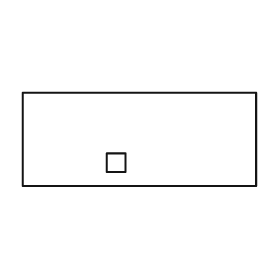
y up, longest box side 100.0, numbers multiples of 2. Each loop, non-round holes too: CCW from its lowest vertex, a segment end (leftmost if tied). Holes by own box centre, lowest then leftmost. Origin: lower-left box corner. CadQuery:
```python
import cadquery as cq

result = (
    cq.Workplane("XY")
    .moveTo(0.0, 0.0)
    .lineTo(100.0, 0.0)
    .lineTo(100.0, 40.0)
    .lineTo(0.0, 40.0)
    .close()
    .moveTo(36.0, 6.0)
    .lineTo(44.0, 6.0)
    .lineTo(44.0, 14.0)
    .lineTo(36.0, 14.0)
    .close()
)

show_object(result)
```